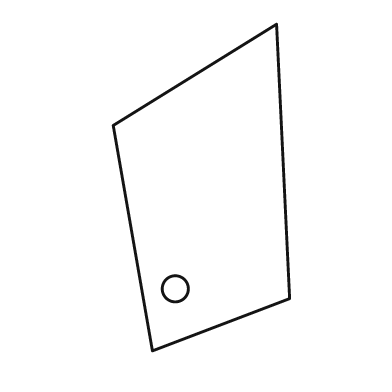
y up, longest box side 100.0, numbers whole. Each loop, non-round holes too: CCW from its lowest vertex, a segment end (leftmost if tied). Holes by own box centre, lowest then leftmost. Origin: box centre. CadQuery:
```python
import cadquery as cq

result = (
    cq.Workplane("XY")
    .moveTo(-15.0, -50.0)
    .lineTo(27.0, -34.0)
    .lineTo(23.0, 50.0)
    .lineTo(-27.0, 19.0)
    .close()
    .moveTo(-8.0, -31.0)
    .circle(4.0)
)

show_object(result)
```